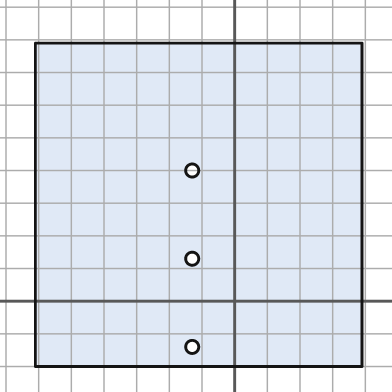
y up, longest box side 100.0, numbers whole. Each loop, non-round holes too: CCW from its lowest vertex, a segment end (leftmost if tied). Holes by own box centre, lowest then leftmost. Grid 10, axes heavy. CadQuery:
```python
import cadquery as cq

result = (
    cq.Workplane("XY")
    .moveTo(-61.0, -20.0)
    .lineTo(39.0, -20.0)
    .lineTo(39.0, 79.0)
    .lineTo(-61.0, 79.0)
    .close()
    .moveTo(-13.0, -14.0)
    .circle(2.0)
    .moveTo(-13.0, 13.0)
    .circle(2.0)
    .moveTo(-13.0, 40.0)
    .circle(2.0)
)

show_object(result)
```